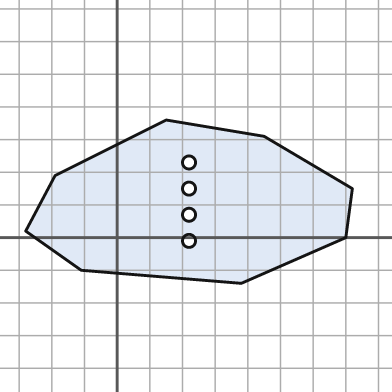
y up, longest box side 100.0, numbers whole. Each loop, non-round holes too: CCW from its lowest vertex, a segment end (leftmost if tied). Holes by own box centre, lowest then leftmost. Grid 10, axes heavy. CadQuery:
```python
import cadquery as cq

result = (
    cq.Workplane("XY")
    .moveTo(38.0, -14.0)
    .lineTo(70.0, 0.0)
    .lineTo(72.0, 15.0)
    .lineTo(45.0, 31.0)
    .lineTo(15.0, 36.0)
    .lineTo(-19.0, 19.0)
    .lineTo(-28.0, 2.0)
    .lineTo(-11.0, -10.0)
    .close()
    .moveTo(22.0, -1.0)
    .circle(2.0)
    .moveTo(22.0, 7.0)
    .circle(2.0)
    .moveTo(22.0, 15.0)
    .circle(2.0)
    .moveTo(22.0, 23.0)
    .circle(2.0)
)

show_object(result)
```